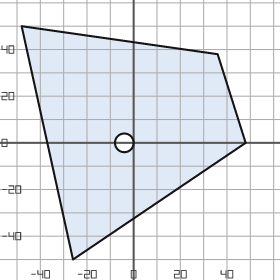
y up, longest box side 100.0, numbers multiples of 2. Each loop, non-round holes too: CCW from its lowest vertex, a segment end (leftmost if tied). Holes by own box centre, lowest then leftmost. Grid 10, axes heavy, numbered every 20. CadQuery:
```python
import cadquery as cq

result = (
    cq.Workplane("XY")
    .moveTo(-26.0, -50.0)
    .lineTo(48.0, 0.0)
    .lineTo(36.0, 38.0)
    .lineTo(-48.0, 50.0)
    .close()
    .moveTo(-4.0, 0.0)
    .circle(4.0)
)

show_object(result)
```